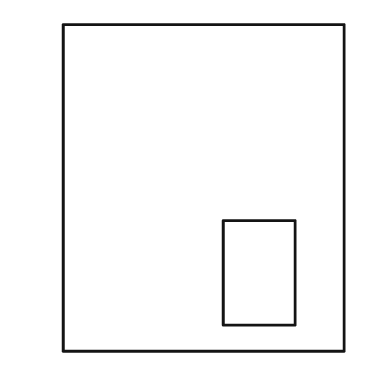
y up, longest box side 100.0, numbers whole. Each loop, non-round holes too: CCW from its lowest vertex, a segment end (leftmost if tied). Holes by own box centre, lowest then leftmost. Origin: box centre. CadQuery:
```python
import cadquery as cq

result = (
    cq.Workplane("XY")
    .moveTo(-43.0, -50.0)
    .lineTo(43.0, -50.0)
    .lineTo(43.0, 50.0)
    .lineTo(-43.0, 50.0)
    .close()
    .moveTo(6.0, -42.0)
    .lineTo(28.0, -42.0)
    .lineTo(28.0, -10.0)
    .lineTo(6.0, -10.0)
    .close()
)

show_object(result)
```